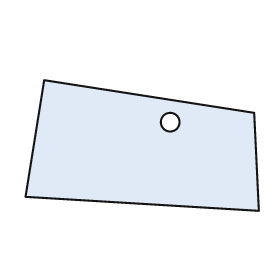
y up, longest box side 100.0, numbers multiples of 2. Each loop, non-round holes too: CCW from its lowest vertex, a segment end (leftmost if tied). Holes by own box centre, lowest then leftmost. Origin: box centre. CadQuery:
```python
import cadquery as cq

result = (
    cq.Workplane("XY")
    .moveTo(50.0, -28.0)
    .lineTo(48.0, 14.0)
    .lineTo(-42.0, 28.0)
    .lineTo(-50.0, -22.0)
    .close()
    .moveTo(12.0, 10.0)
    .circle(4.0)
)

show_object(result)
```